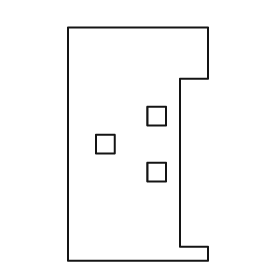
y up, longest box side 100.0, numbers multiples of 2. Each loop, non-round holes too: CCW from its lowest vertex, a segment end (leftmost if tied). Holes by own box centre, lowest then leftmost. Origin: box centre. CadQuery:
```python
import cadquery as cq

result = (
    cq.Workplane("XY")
    .moveTo(-30.0, -50.0)
    .lineTo(30.0, -50.0)
    .lineTo(30.0, -44.0)
    .lineTo(18.0, -44.0)
    .lineTo(18.0, 28.0)
    .lineTo(30.0, 28.0)
    .lineTo(30.0, 50.0)
    .lineTo(-30.0, 50.0)
    .close()
    .moveTo(4.0, -16.0)
    .lineTo(12.0, -16.0)
    .lineTo(12.0, -8.0)
    .lineTo(4.0, -8.0)
    .close()
    .moveTo(-18.0, -4.0)
    .lineTo(-10.0, -4.0)
    .lineTo(-10.0, 4.0)
    .lineTo(-18.0, 4.0)
    .close()
    .moveTo(4.0, 8.0)
    .lineTo(12.0, 8.0)
    .lineTo(12.0, 16.0)
    .lineTo(4.0, 16.0)
    .close()
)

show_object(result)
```